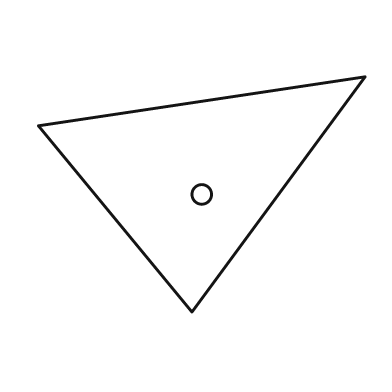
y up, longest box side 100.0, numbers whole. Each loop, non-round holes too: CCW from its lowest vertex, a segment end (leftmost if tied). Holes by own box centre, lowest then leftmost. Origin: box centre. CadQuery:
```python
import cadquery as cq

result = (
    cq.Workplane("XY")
    .moveTo(-3.0, -36.0)
    .lineTo(50.0, 36.0)
    .lineTo(-50.0, 21.0)
    .close()
    .moveTo(0.0, 0.0)
    .circle(3.0)
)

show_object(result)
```